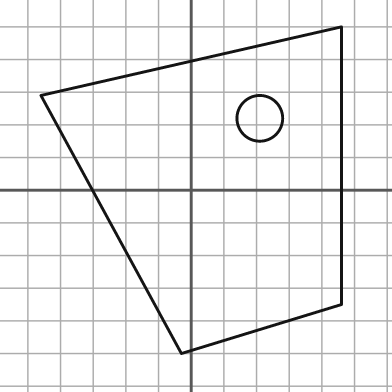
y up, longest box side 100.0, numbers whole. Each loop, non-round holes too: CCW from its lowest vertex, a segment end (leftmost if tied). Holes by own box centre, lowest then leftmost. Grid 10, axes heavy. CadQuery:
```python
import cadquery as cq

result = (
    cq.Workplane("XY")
    .moveTo(-3.0, -50.0)
    .lineTo(46.0, -35.0)
    .lineTo(46.0, 50.0)
    .lineTo(-46.0, 29.0)
    .close()
    .moveTo(21.0, 22.0)
    .circle(7.0)
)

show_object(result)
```